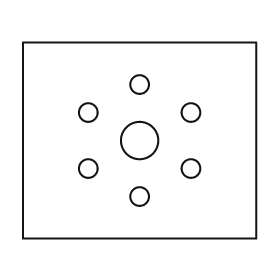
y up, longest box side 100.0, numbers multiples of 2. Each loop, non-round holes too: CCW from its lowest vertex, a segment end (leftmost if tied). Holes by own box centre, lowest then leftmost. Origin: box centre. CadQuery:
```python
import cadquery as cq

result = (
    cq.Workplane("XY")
    .moveTo(-50.0, -42.0)
    .lineTo(50.0, -42.0)
    .lineTo(50.0, 42.0)
    .lineTo(-50.0, 42.0)
    .close()
    .moveTo(0.0, -24.0)
    .circle(4.0)
    .moveTo(-22.0, -12.0)
    .circle(4.0)
    .moveTo(22.0, -12.0)
    .circle(4.0)
    .moveTo(0.0, 0.0)
    .circle(8.0)
    .moveTo(-22.0, 12.0)
    .circle(4.0)
    .moveTo(22.0, 12.0)
    .circle(4.0)
    .moveTo(0.0, 24.0)
    .circle(4.0)
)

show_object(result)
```